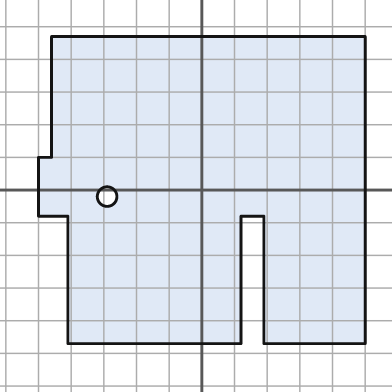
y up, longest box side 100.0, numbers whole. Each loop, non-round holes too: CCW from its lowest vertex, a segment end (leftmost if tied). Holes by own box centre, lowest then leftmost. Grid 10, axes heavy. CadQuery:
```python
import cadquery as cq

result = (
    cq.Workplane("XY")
    .moveTo(-41.0, -47.0)
    .lineTo(12.0, -47.0)
    .lineTo(12.0, -8.0)
    .lineTo(19.0, -8.0)
    .lineTo(19.0, -47.0)
    .lineTo(50.0, -47.0)
    .lineTo(50.0, 47.0)
    .lineTo(-46.0, 47.0)
    .lineTo(-46.0, 10.0)
    .lineTo(-50.0, 10.0)
    .lineTo(-50.0, -8.0)
    .lineTo(-41.0, -8.0)
    .close()
    .moveTo(-29.0, -2.0)
    .circle(3.0)
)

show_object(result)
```